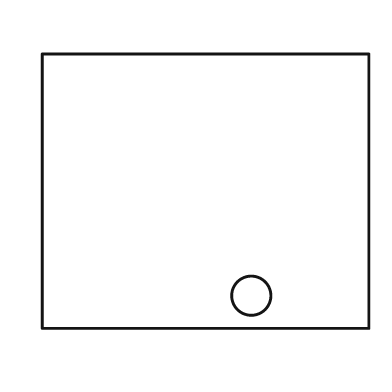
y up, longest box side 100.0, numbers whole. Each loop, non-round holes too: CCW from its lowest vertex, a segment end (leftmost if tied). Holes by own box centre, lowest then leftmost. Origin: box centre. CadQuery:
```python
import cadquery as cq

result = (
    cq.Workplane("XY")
    .moveTo(-50.0, -42.0)
    .lineTo(50.0, -42.0)
    .lineTo(50.0, 42.0)
    .lineTo(-50.0, 42.0)
    .close()
    .moveTo(14.0, -32.0)
    .circle(6.0)
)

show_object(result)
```